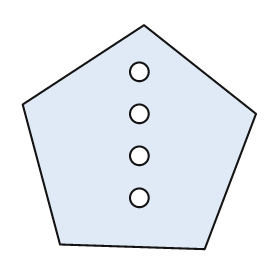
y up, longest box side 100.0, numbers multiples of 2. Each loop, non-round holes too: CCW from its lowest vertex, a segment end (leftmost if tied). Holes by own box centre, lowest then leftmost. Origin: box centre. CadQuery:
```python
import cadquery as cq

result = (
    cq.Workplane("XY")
    .moveTo(28.0, -48.0)
    .lineTo(50.0, 10.0)
    .lineTo(2.0, 48.0)
    .lineTo(-50.0, 14.0)
    .lineTo(-34.0, -46.0)
    .close()
    .moveTo(0.0, -26.0)
    .circle(4.0)
    .moveTo(0.0, -8.0)
    .circle(4.0)
    .moveTo(0.0, 10.0)
    .circle(4.0)
    .moveTo(0.0, 28.0)
    .circle(4.0)
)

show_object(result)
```